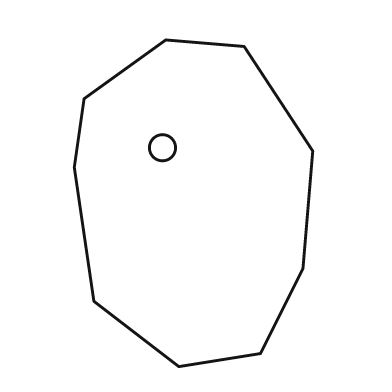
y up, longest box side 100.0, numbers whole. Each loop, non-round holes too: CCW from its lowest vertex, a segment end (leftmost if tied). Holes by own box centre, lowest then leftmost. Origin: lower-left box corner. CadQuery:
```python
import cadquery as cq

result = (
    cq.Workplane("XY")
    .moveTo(32.0, 0.0)
    .lineTo(57.0, 4.0)
    .lineTo(70.0, 30.0)
    .lineTo(73.0, 66.0)
    .lineTo(52.0, 98.0)
    .lineTo(28.0, 100.0)
    .lineTo(3.0, 82.0)
    .lineTo(0.0, 61.0)
    .lineTo(6.0, 20.0)
    .close()
    .moveTo(27.0, 67.0)
    .circle(4.0)
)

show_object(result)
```